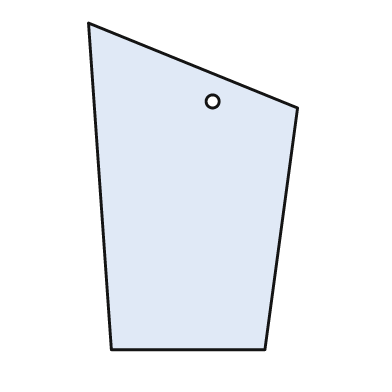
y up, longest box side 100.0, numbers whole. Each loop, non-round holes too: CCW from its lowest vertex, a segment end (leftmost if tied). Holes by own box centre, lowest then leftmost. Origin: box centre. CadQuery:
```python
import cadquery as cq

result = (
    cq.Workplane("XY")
    .moveTo(-25.0, -50.0)
    .lineTo(22.0, -50.0)
    .lineTo(32.0, 24.0)
    .lineTo(-32.0, 50.0)
    .close()
    .moveTo(6.0, 26.0)
    .circle(2.0)
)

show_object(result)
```